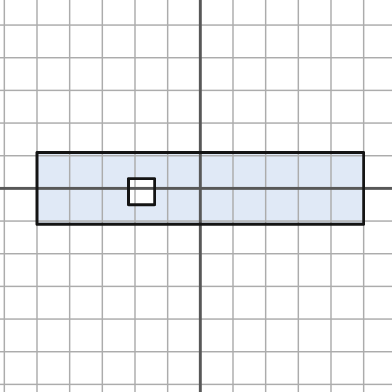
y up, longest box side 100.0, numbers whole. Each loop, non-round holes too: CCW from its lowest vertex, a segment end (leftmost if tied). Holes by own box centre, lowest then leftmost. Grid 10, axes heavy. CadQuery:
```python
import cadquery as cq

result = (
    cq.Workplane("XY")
    .moveTo(-50.0, -11.0)
    .lineTo(50.0, -11.0)
    .lineTo(50.0, 11.0)
    .lineTo(-50.0, 11.0)
    .close()
    .moveTo(-22.0, -5.0)
    .lineTo(-14.0, -5.0)
    .lineTo(-14.0, 3.0)
    .lineTo(-22.0, 3.0)
    .close()
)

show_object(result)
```